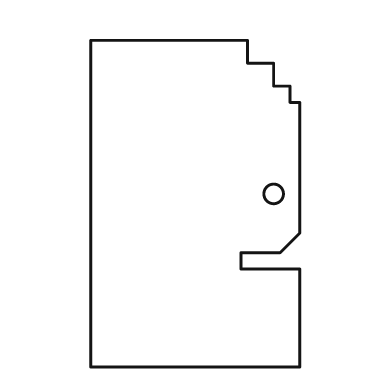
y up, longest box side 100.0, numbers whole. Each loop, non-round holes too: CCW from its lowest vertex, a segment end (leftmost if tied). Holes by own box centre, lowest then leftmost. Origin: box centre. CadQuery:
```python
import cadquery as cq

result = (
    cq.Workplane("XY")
    .moveTo(-32.0, -50.0)
    .lineTo(32.0, -50.0)
    .lineTo(32.0, -20.0)
    .lineTo(14.0, -20.0)
    .lineTo(14.0, -15.0)
    .lineTo(26.0, -15.0)
    .lineTo(32.0, -9.0)
    .lineTo(32.0, 31.0)
    .lineTo(29.0, 31.0)
    .lineTo(29.0, 36.0)
    .lineTo(24.0, 36.0)
    .lineTo(24.0, 43.0)
    .lineTo(16.0, 43.0)
    .lineTo(16.0, 50.0)
    .lineTo(-32.0, 50.0)
    .close()
    .moveTo(24.0, 3.0)
    .circle(3.0)
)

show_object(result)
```